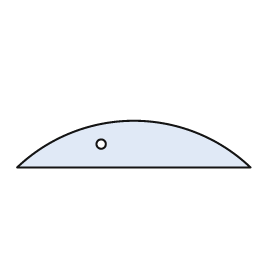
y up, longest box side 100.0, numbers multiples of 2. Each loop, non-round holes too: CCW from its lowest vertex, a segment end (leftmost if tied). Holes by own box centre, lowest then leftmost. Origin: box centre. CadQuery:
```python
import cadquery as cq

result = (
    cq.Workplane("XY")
    .moveTo(-50.0, -10.0)
    .lineTo(50.0, -10.0)
    .threePointArc((0.0, 10.0), (-50.0, -10.0))
    .close()
    .moveTo(-14.0, 0.0)
    .circle(2.0)
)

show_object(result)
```